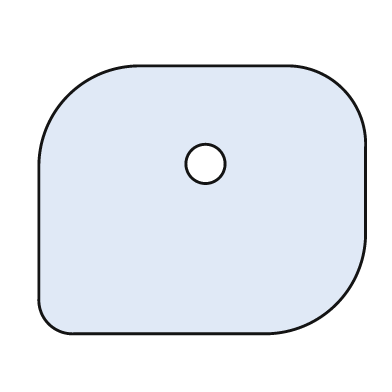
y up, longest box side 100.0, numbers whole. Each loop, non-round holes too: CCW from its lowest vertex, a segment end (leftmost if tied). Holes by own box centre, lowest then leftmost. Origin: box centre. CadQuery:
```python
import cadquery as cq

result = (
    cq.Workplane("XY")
    .moveTo(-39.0, -41.0)
    .lineTo(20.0, -41.0)
    .threePointArc((41.0, -32.0), (50.0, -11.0))
    .lineTo(50.0, 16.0)
    .threePointArc((43.0, 34.0), (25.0, 41.0))
    .lineTo(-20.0, 41.0)
    .threePointArc((-41.0, 32.0), (-50.0, 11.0))
    .lineTo(-50.0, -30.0)
    .threePointArc((-47.0, -38.0), (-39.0, -41.0))
    .close()
    .moveTo(1.0, 11.0)
    .circle(6.0)
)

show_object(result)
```